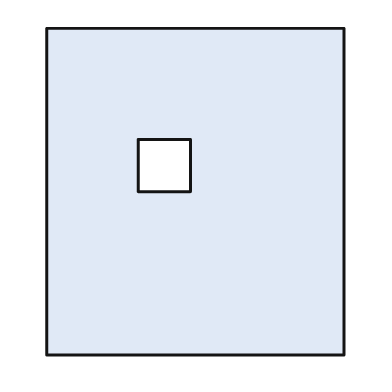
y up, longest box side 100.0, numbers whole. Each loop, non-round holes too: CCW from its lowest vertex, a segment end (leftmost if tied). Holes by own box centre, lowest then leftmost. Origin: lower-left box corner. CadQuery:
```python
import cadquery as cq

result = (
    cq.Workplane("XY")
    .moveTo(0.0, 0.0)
    .lineTo(91.0, 0.0)
    .lineTo(91.0, 100.0)
    .lineTo(0.0, 100.0)
    .close()
    .moveTo(28.0, 50.0)
    .lineTo(44.0, 50.0)
    .lineTo(44.0, 66.0)
    .lineTo(28.0, 66.0)
    .close()
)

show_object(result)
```